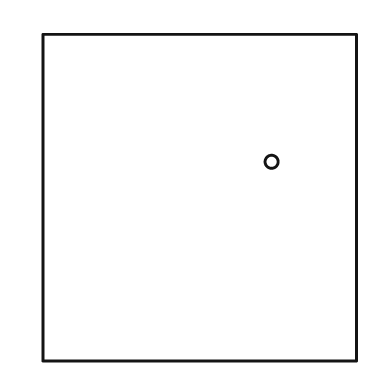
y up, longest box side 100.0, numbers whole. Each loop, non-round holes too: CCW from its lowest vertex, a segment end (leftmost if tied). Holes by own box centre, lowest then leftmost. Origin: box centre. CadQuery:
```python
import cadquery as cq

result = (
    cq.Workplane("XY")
    .moveTo(-48.0, -50.0)
    .lineTo(48.0, -50.0)
    .lineTo(48.0, 50.0)
    .lineTo(-48.0, 50.0)
    .close()
    .moveTo(22.0, 11.0)
    .circle(2.0)
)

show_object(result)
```